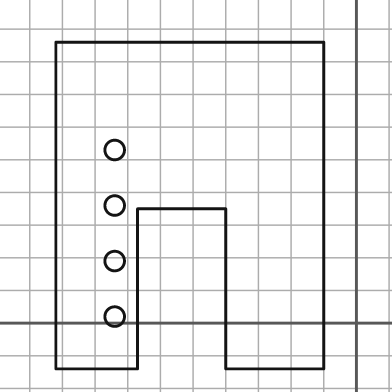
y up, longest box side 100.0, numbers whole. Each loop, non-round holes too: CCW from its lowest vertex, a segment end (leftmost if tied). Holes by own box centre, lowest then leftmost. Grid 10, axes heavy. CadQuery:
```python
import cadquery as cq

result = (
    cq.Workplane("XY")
    .moveTo(-92.0, -14.0)
    .lineTo(-67.0, -14.0)
    .lineTo(-67.0, 35.0)
    .lineTo(-40.0, 35.0)
    .lineTo(-40.0, -14.0)
    .lineTo(-10.0, -14.0)
    .lineTo(-10.0, 86.0)
    .lineTo(-92.0, 86.0)
    .close()
    .moveTo(-74.0, 2.0)
    .circle(3.0)
    .moveTo(-74.0, 19.0)
    .circle(3.0)
    .moveTo(-74.0, 36.0)
    .circle(3.0)
    .moveTo(-74.0, 53.0)
    .circle(3.0)
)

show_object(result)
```